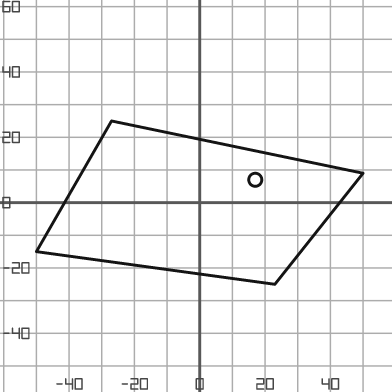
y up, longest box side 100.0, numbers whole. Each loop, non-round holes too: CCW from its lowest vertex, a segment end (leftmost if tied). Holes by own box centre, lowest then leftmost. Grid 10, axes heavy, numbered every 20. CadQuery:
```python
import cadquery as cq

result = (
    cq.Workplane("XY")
    .moveTo(23.0, -25.0)
    .lineTo(50.0, 9.0)
    .lineTo(-27.0, 25.0)
    .lineTo(-50.0, -15.0)
    .close()
    .moveTo(17.0, 7.0)
    .circle(2.0)
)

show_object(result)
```